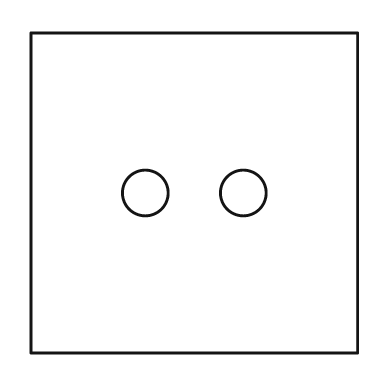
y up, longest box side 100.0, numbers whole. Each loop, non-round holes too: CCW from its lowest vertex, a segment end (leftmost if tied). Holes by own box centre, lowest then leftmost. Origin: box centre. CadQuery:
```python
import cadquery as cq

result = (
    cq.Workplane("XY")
    .moveTo(-50.0, -49.0)
    .lineTo(50.0, -49.0)
    .lineTo(50.0, 49.0)
    .lineTo(-50.0, 49.0)
    .close()
    .moveTo(-15.0, 0.0)
    .circle(7.0)
    .moveTo(15.0, 0.0)
    .circle(7.0)
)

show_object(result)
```